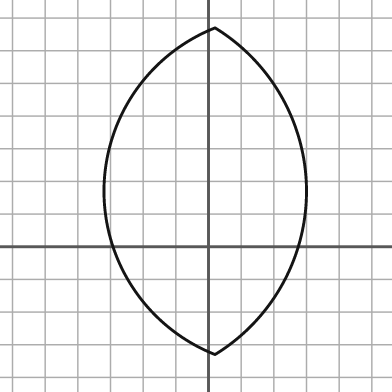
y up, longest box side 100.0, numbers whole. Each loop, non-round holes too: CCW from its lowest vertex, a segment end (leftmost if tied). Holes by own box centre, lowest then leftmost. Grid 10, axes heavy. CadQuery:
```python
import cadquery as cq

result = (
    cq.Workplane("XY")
    .moveTo(2.0, -33.0)
    .threePointArc((30.0, 17.0), (2.0, 67.0))
    .threePointArc((-32.0, 17.0), (2.0, -33.0))
    .close()
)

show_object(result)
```